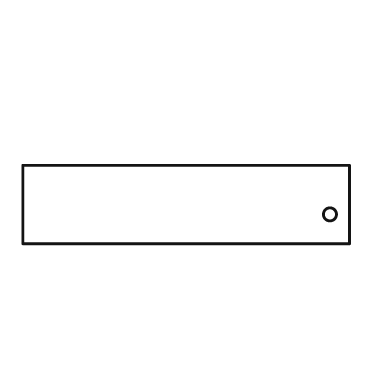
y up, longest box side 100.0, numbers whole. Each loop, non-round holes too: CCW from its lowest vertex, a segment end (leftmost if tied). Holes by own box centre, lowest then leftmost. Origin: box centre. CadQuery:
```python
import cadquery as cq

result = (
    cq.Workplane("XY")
    .moveTo(-50.0, -12.0)
    .lineTo(50.0, -12.0)
    .lineTo(50.0, 12.0)
    .lineTo(-50.0, 12.0)
    .close()
    .moveTo(44.0, -3.0)
    .circle(2.0)
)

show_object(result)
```